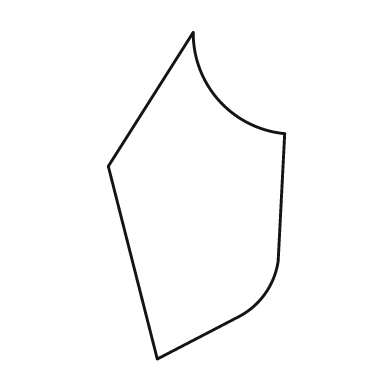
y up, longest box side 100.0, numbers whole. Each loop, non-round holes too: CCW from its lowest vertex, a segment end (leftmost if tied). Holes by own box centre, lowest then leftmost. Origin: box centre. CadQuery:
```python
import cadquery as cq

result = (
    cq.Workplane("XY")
    .moveTo(-12.0, -50.0)
    .lineTo(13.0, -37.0)
    .threePointArc((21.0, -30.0), (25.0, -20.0))
    .lineTo(27.0, 19.0)
    .threePointArc((7.0, 29.0), (-1.0, 50.0))
    .lineTo(-27.0, 9.0)
    .close()
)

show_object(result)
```